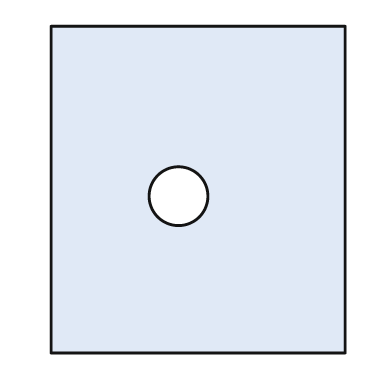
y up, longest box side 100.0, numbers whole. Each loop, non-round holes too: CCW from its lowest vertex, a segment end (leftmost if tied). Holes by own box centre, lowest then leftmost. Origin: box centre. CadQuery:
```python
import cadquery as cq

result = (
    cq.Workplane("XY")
    .moveTo(-45.0, -50.0)
    .lineTo(45.0, -50.0)
    .lineTo(45.0, 50.0)
    .lineTo(-45.0, 50.0)
    .close()
    .moveTo(-6.0, -2.0)
    .circle(9.0)
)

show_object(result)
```